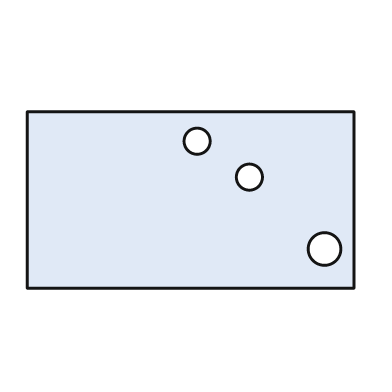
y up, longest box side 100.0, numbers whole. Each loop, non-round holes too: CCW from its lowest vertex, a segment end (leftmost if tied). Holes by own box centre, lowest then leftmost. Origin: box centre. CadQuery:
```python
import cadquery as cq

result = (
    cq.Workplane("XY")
    .moveTo(-50.0, -27.0)
    .lineTo(50.0, -27.0)
    .lineTo(50.0, 27.0)
    .lineTo(-50.0, 27.0)
    .close()
    .moveTo(41.0, -15.0)
    .circle(5.0)
    .moveTo(18.0, 7.0)
    .circle(4.0)
    .moveTo(2.0, 18.0)
    .circle(4.0)
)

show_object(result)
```